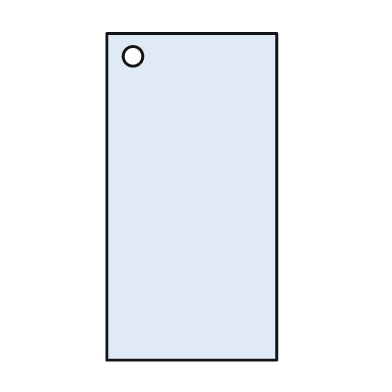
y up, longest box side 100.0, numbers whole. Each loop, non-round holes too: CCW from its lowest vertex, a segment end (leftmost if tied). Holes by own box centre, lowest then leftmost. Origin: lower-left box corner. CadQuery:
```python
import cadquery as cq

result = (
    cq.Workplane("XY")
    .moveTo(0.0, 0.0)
    .lineTo(52.0, 0.0)
    .lineTo(52.0, 100.0)
    .lineTo(0.0, 100.0)
    .close()
    .moveTo(8.0, 93.0)
    .circle(3.0)
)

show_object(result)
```